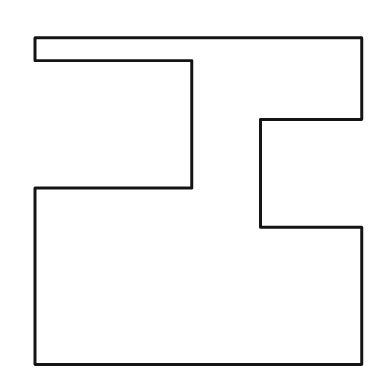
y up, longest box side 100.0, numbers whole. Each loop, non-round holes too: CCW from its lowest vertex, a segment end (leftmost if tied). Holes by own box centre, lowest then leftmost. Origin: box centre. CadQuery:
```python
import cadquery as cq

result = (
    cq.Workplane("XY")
    .moveTo(-50.0, -50.0)
    .lineTo(50.0, -50.0)
    .lineTo(50.0, -8.0)
    .lineTo(19.0, -8.0)
    .lineTo(19.0, 25.0)
    .lineTo(50.0, 25.0)
    .lineTo(50.0, 50.0)
    .lineTo(-50.0, 50.0)
    .lineTo(-50.0, 43.0)
    .lineTo(-2.0, 43.0)
    .lineTo(-2.0, 4.0)
    .lineTo(-50.0, 4.0)
    .close()
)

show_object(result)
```